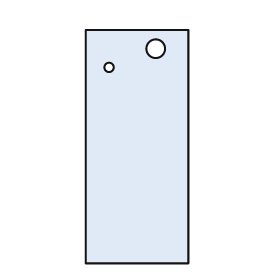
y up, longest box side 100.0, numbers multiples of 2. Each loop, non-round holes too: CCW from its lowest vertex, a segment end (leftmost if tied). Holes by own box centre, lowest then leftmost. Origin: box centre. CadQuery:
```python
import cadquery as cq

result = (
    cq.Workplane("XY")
    .moveTo(-22.0, -50.0)
    .lineTo(22.0, -50.0)
    .lineTo(22.0, 50.0)
    .lineTo(-22.0, 50.0)
    .close()
    .moveTo(-12.0, 34.0)
    .circle(2.0)
    .moveTo(8.0, 42.0)
    .circle(4.0)
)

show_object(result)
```